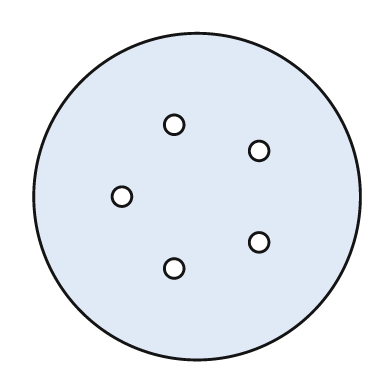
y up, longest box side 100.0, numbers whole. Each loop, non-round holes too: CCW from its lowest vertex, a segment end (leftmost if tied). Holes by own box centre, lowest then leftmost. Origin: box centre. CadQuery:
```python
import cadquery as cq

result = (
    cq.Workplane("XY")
    .moveTo(0.0, 0.0)
    .circle(50.0)
    .moveTo(-7.0, -22.0)
    .circle(3.0)
    .moveTo(19.0, -14.0)
    .circle(3.0)
    .moveTo(-23.0, 0.0)
    .circle(3.0)
    .moveTo(19.0, 14.0)
    .circle(3.0)
    .moveTo(-7.0, 22.0)
    .circle(3.0)
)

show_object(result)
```